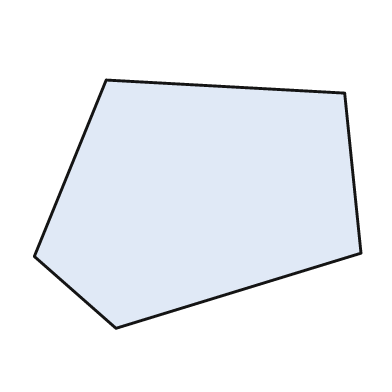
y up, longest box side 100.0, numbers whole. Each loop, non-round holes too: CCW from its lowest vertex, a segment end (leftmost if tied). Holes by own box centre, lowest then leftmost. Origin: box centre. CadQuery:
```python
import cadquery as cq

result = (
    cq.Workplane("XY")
    .moveTo(-25.0, -38.0)
    .lineTo(50.0, -15.0)
    .lineTo(45.0, 34.0)
    .lineTo(-28.0, 38.0)
    .lineTo(-50.0, -16.0)
    .close()
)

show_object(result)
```